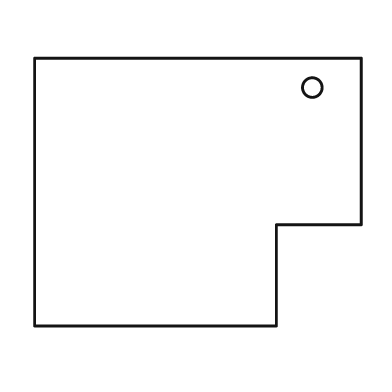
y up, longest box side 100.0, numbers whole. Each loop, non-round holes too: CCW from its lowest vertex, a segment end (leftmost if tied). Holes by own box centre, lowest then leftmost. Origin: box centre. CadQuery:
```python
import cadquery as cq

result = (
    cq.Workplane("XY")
    .moveTo(-50.0, -41.0)
    .lineTo(24.0, -41.0)
    .lineTo(24.0, -10.0)
    .lineTo(50.0, -10.0)
    .lineTo(50.0, 41.0)
    .lineTo(-50.0, 41.0)
    .close()
    .moveTo(35.0, 32.0)
    .circle(3.0)
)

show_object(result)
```